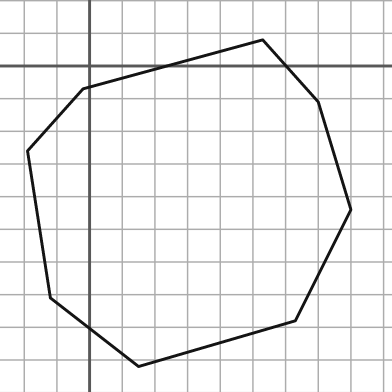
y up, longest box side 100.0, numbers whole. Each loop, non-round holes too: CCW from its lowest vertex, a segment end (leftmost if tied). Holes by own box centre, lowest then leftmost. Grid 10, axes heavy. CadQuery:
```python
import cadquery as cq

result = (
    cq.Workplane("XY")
    .moveTo(15.0, -92.0)
    .lineTo(63.0, -78.0)
    .lineTo(80.0, -44.0)
    .lineTo(70.0, -11.0)
    .lineTo(53.0, 8.0)
    .lineTo(-2.0, -7.0)
    .lineTo(-19.0, -26.0)
    .lineTo(-12.0, -71.0)
    .close()
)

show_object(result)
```